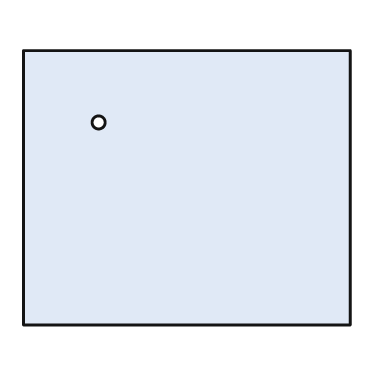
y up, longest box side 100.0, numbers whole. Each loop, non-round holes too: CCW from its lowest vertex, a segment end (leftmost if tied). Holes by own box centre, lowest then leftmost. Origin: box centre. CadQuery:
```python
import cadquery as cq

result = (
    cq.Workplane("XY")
    .moveTo(-50.0, -42.0)
    .lineTo(50.0, -42.0)
    .lineTo(50.0, 42.0)
    .lineTo(-50.0, 42.0)
    .close()
    .moveTo(-27.0, 20.0)
    .circle(2.0)
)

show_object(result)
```